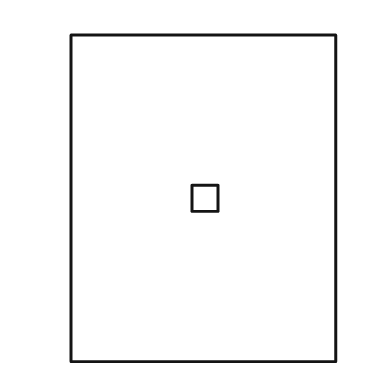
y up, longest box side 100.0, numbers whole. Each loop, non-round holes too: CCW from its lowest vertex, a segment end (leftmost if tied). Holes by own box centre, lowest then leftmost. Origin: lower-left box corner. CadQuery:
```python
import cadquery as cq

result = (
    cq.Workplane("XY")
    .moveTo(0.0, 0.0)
    .lineTo(81.0, 0.0)
    .lineTo(81.0, 100.0)
    .lineTo(0.0, 100.0)
    .close()
    .moveTo(37.0, 46.0)
    .lineTo(45.0, 46.0)
    .lineTo(45.0, 54.0)
    .lineTo(37.0, 54.0)
    .close()
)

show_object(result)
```